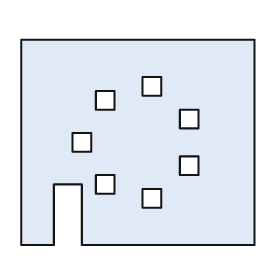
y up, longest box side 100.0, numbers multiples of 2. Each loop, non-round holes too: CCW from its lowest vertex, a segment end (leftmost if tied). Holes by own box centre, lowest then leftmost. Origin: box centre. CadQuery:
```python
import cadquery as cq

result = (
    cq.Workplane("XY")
    .moveTo(-50.0, -44.0)
    .lineTo(-36.0, -44.0)
    .lineTo(-36.0, -18.0)
    .lineTo(-24.0, -18.0)
    .lineTo(-24.0, -44.0)
    .lineTo(50.0, -44.0)
    .lineTo(50.0, 44.0)
    .lineTo(-50.0, 44.0)
    .close()
    .moveTo(2.0, -28.0)
    .lineTo(10.0, -28.0)
    .lineTo(10.0, -20.0)
    .lineTo(2.0, -20.0)
    .close()
    .moveTo(-18.0, -22.0)
    .lineTo(-10.0, -22.0)
    .lineTo(-10.0, -14.0)
    .lineTo(-18.0, -14.0)
    .close()
    .moveTo(18.0, -14.0)
    .lineTo(26.0, -14.0)
    .lineTo(26.0, -6.0)
    .lineTo(18.0, -6.0)
    .close()
    .moveTo(-28.0, -4.0)
    .lineTo(-20.0, -4.0)
    .lineTo(-20.0, 4.0)
    .lineTo(-28.0, 4.0)
    .close()
    .moveTo(18.0, 6.0)
    .lineTo(26.0, 6.0)
    .lineTo(26.0, 14.0)
    .lineTo(18.0, 14.0)
    .close()
    .moveTo(-18.0, 14.0)
    .lineTo(-10.0, 14.0)
    .lineTo(-10.0, 22.0)
    .lineTo(-18.0, 22.0)
    .close()
    .moveTo(2.0, 20.0)
    .lineTo(10.0, 20.0)
    .lineTo(10.0, 28.0)
    .lineTo(2.0, 28.0)
    .close()
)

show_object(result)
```